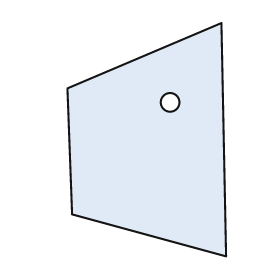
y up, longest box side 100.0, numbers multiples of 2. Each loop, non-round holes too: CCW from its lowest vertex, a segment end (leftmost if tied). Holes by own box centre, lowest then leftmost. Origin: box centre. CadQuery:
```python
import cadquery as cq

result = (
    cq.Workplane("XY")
    .moveTo(34.0, -50.0)
    .lineTo(32.0, 50.0)
    .lineTo(-34.0, 22.0)
    .lineTo(-32.0, -32.0)
    .close()
    .moveTo(10.0, 16.0)
    .circle(4.0)
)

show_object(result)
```